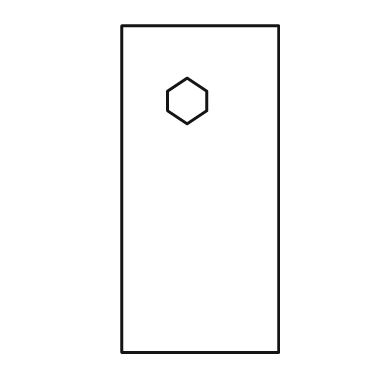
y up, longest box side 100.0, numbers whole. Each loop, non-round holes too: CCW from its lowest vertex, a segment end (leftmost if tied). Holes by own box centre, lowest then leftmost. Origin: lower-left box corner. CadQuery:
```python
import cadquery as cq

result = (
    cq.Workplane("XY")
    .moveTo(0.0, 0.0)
    .lineTo(48.0, 0.0)
    .lineTo(48.0, 100.0)
    .lineTo(0.0, 100.0)
    .close()
    .moveTo(20.0, 70.0)
    .lineTo(26.0, 74.0)
    .lineTo(26.0, 80.0)
    .lineTo(20.0, 84.0)
    .lineTo(14.0, 80.0)
    .lineTo(14.0, 74.0)
    .close()
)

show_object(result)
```